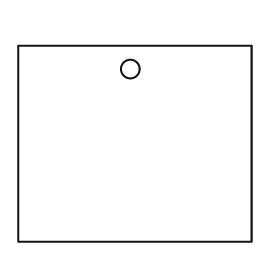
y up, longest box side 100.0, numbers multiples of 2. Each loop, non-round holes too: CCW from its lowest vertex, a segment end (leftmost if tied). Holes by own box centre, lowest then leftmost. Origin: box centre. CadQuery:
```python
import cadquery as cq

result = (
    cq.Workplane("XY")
    .moveTo(-50.0, -42.0)
    .lineTo(50.0, -42.0)
    .lineTo(50.0, 42.0)
    .lineTo(-50.0, 42.0)
    .close()
    .moveTo(-2.0, 32.0)
    .circle(4.0)
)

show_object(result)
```